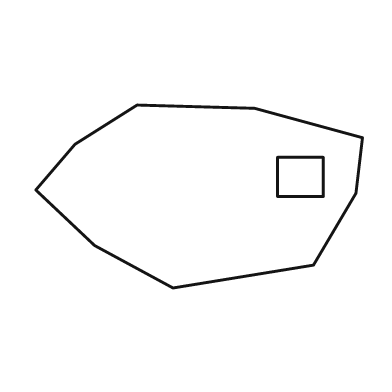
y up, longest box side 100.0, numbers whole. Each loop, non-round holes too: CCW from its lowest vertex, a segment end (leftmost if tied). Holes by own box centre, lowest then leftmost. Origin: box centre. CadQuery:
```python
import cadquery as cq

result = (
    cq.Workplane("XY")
    .moveTo(-8.0, -28.0)
    .lineTo(35.0, -21.0)
    .lineTo(48.0, 1.0)
    .lineTo(50.0, 18.0)
    .lineTo(17.0, 27.0)
    .lineTo(-19.0, 28.0)
    .lineTo(-38.0, 16.0)
    .lineTo(-50.0, 2.0)
    .lineTo(-32.0, -15.0)
    .close()
    .moveTo(24.0, 0.0)
    .lineTo(38.0, 0.0)
    .lineTo(38.0, 12.0)
    .lineTo(24.0, 12.0)
    .close()
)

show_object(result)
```